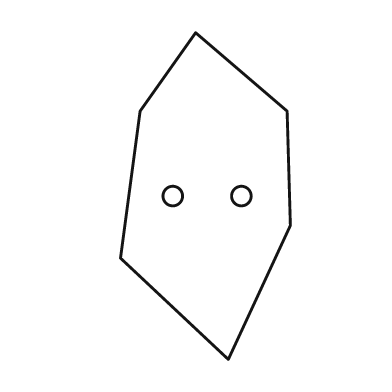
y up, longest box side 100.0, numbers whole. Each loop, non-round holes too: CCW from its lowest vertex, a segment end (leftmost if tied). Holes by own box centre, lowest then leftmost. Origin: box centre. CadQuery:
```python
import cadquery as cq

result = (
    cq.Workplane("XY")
    .moveTo(7.0, -50.0)
    .lineTo(26.0, -9.0)
    .lineTo(25.0, 26.0)
    .lineTo(-3.0, 50.0)
    .lineTo(-20.0, 26.0)
    .lineTo(-26.0, -19.0)
    .close()
    .moveTo(-10.0, 0.0)
    .circle(3.0)
    .moveTo(11.0, 0.0)
    .circle(3.0)
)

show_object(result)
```